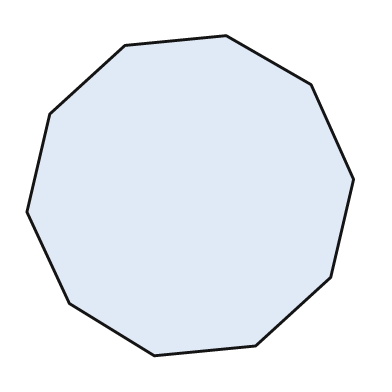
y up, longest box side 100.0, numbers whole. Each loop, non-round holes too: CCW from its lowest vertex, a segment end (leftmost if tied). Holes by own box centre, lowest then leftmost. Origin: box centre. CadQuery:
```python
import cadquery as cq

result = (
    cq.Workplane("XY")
    .moveTo(-11.0, -49.0)
    .lineTo(20.0, -46.0)
    .lineTo(43.0, -25.0)
    .lineTo(50.0, 5.0)
    .lineTo(37.0, 34.0)
    .lineTo(11.0, 49.0)
    .lineTo(-20.0, 46.0)
    .lineTo(-43.0, 25.0)
    .lineTo(-50.0, -5.0)
    .lineTo(-37.0, -33.0)
    .close()
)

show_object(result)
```